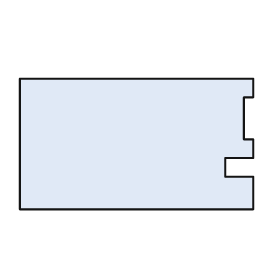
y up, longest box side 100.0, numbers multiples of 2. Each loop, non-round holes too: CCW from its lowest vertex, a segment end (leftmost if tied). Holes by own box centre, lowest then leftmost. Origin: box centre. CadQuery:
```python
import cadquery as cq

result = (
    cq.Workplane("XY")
    .moveTo(-50.0, -28.0)
    .lineTo(50.0, -28.0)
    .lineTo(50.0, -14.0)
    .lineTo(38.0, -14.0)
    .lineTo(38.0, -6.0)
    .lineTo(50.0, -6.0)
    .lineTo(50.0, 2.0)
    .lineTo(46.0, 2.0)
    .lineTo(46.0, 20.0)
    .lineTo(50.0, 20.0)
    .lineTo(50.0, 28.0)
    .lineTo(-50.0, 28.0)
    .close()
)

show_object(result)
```